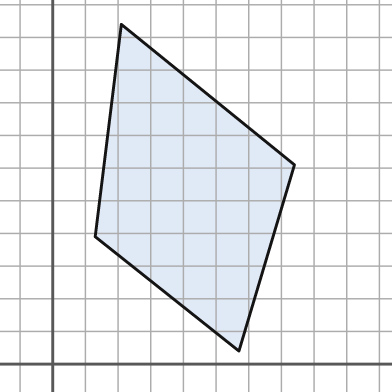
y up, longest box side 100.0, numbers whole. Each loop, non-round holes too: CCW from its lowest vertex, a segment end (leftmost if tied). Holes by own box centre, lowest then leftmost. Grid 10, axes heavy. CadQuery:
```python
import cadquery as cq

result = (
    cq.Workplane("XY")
    .moveTo(57.0, 4.0)
    .lineTo(74.0, 61.0)
    .lineTo(21.0, 104.0)
    .lineTo(13.0, 39.0)
    .close()
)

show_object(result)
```